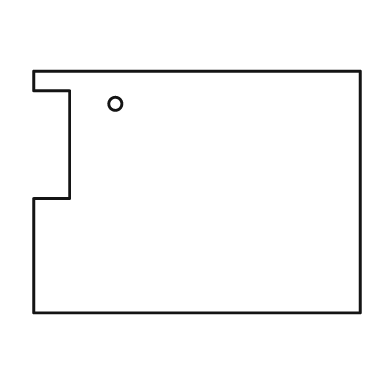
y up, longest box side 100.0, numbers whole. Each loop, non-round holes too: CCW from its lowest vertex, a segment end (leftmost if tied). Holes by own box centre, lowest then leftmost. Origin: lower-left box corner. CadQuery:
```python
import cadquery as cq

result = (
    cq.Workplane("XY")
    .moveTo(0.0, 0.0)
    .lineTo(100.0, 0.0)
    .lineTo(100.0, 74.0)
    .lineTo(0.0, 74.0)
    .lineTo(0.0, 68.0)
    .lineTo(11.0, 68.0)
    .lineTo(11.0, 35.0)
    .lineTo(0.0, 35.0)
    .close()
    .moveTo(25.0, 64.0)
    .circle(2.0)
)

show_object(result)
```